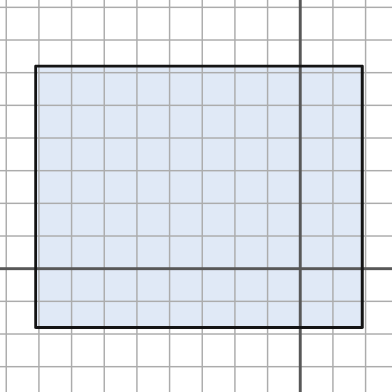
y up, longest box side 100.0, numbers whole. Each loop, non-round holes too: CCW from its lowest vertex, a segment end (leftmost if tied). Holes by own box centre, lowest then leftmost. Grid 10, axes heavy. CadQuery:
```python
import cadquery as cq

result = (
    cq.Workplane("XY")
    .moveTo(-81.0, -18.0)
    .lineTo(19.0, -18.0)
    .lineTo(19.0, 62.0)
    .lineTo(-81.0, 62.0)
    .close()
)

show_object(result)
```